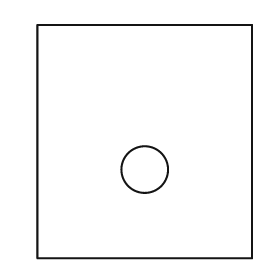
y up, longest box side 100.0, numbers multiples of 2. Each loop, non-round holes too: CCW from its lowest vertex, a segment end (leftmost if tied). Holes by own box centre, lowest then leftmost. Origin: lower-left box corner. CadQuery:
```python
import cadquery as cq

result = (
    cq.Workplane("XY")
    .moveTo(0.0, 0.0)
    .lineTo(92.0, 0.0)
    .lineTo(92.0, 100.0)
    .lineTo(0.0, 100.0)
    .close()
    .moveTo(46.0, 38.0)
    .circle(10.0)
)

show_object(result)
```